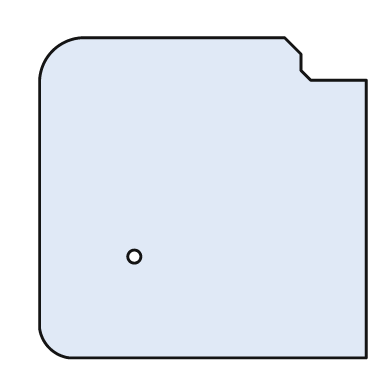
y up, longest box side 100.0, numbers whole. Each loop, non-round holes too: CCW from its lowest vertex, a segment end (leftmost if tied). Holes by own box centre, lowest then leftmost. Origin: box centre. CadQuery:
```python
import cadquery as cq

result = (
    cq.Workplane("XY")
    .moveTo(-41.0, -49.0)
    .lineTo(50.0, -49.0)
    .lineTo(50.0, 36.0)
    .lineTo(33.0, 36.0)
    .lineTo(30.0, 39.0)
    .lineTo(30.0, 44.0)
    .lineTo(25.0, 49.0)
    .lineTo(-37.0, 49.0)
    .threePointArc((-46.0, 45.0), (-50.0, 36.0))
    .lineTo(-50.0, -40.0)
    .threePointArc((-47.0, -46.0), (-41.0, -49.0))
    .close()
    .moveTo(-21.0, -18.0)
    .circle(2.0)
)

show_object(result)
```